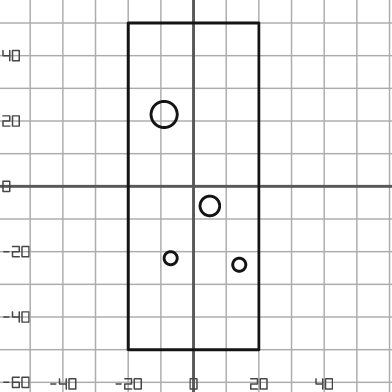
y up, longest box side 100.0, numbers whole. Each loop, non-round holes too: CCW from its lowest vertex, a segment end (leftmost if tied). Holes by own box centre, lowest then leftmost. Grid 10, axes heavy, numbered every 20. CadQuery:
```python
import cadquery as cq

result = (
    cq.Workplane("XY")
    .moveTo(-20.0, -50.0)
    .lineTo(20.0, -50.0)
    .lineTo(20.0, 50.0)
    .lineTo(-20.0, 50.0)
    .close()
    .moveTo(14.0, -24.0)
    .circle(2.0)
    .moveTo(-7.0, -22.0)
    .circle(2.0)
    .moveTo(5.0, -6.0)
    .circle(3.0)
    .moveTo(-9.0, 22.0)
    .circle(4.0)
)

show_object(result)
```